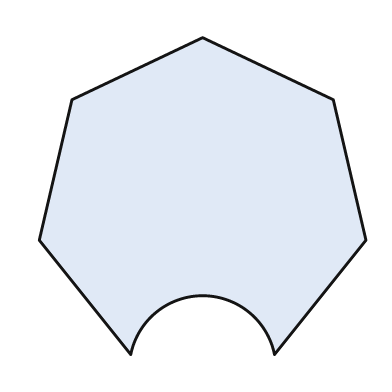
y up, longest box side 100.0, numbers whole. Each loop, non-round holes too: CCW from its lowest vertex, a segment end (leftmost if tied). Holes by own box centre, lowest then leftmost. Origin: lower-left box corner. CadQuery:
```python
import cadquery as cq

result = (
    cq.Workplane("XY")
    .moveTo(28.0, 0.0)
    .threePointArc((50.0, 18.0), (72.0, 0.0))
    .lineTo(100.0, 35.0)
    .lineTo(90.0, 78.0)
    .lineTo(50.0, 97.0)
    .lineTo(10.0, 78.0)
    .lineTo(0.0, 35.0)
    .close()
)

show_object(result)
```